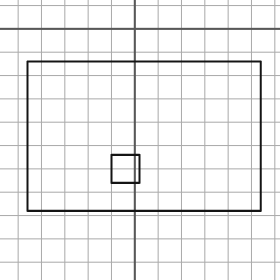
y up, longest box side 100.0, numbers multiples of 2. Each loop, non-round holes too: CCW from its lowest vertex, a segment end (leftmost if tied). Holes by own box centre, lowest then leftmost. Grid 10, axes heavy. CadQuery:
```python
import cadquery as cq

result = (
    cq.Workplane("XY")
    .moveTo(-46.0, -78.0)
    .lineTo(54.0, -78.0)
    .lineTo(54.0, -14.0)
    .lineTo(-46.0, -14.0)
    .close()
    .moveTo(-10.0, -66.0)
    .lineTo(2.0, -66.0)
    .lineTo(2.0, -54.0)
    .lineTo(-10.0, -54.0)
    .close()
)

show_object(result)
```